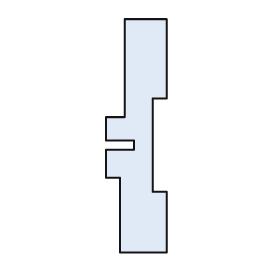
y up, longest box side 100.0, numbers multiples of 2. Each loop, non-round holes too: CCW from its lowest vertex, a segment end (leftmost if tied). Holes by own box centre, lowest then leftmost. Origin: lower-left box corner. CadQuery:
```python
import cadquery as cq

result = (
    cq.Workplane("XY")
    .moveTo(6.0, 0.0)
    .lineTo(26.0, 0.0)
    .lineTo(26.0, 26.0)
    .lineTo(20.0, 26.0)
    .lineTo(20.0, 66.0)
    .lineTo(26.0, 66.0)
    .lineTo(26.0, 100.0)
    .lineTo(8.0, 100.0)
    .lineTo(8.0, 58.0)
    .lineTo(0.0, 58.0)
    .lineTo(0.0, 48.0)
    .lineTo(12.0, 48.0)
    .lineTo(12.0, 44.0)
    .lineTo(0.0, 44.0)
    .lineTo(0.0, 32.0)
    .lineTo(6.0, 32.0)
    .close()
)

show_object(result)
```